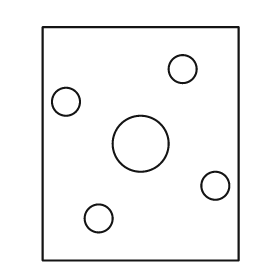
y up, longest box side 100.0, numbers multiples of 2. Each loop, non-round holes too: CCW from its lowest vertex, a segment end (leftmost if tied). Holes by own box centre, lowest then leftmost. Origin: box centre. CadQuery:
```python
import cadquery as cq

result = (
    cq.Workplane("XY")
    .moveTo(-42.0, -50.0)
    .lineTo(42.0, -50.0)
    .lineTo(42.0, 50.0)
    .lineTo(-42.0, 50.0)
    .close()
    .moveTo(-18.0, -32.0)
    .circle(6.0)
    .moveTo(32.0, -18.0)
    .circle(6.0)
    .moveTo(0.0, 0.0)
    .circle(12.0)
    .moveTo(-32.0, 18.0)
    .circle(6.0)
    .moveTo(18.0, 32.0)
    .circle(6.0)
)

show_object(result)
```